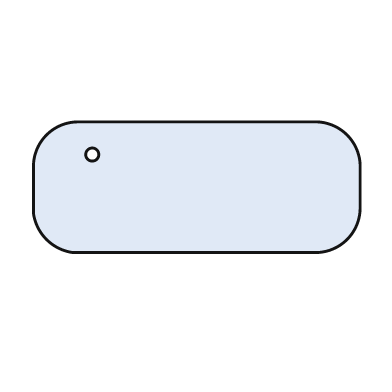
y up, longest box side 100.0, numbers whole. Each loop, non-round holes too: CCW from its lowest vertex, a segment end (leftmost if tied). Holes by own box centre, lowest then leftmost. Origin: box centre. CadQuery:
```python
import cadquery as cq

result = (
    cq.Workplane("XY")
    .moveTo(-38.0, -20.0)
    .lineTo(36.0, -20.0)
    .threePointArc((46.0, -16.0), (50.0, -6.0))
    .lineTo(50.0, 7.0)
    .threePointArc((46.0, 16.0), (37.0, 20.0))
    .lineTo(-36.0, 20.0)
    .threePointArc((-46.0, 16.0), (-50.0, 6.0))
    .lineTo(-50.0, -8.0)
    .threePointArc((-46.0, -16.0), (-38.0, -20.0))
    .close()
    .moveTo(-32.0, 10.0)
    .circle(2.0)
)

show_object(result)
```